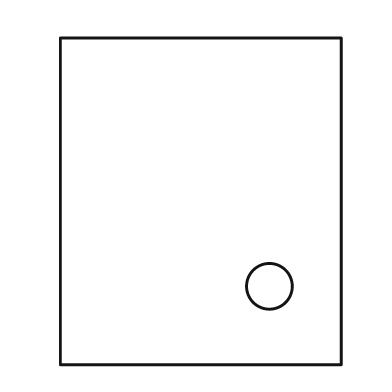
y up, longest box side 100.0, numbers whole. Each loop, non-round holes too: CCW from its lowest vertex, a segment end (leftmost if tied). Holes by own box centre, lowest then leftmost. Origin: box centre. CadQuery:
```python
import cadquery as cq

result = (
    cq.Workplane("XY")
    .moveTo(-43.0, -50.0)
    .lineTo(43.0, -50.0)
    .lineTo(43.0, 50.0)
    .lineTo(-43.0, 50.0)
    .close()
    .moveTo(21.0, -26.0)
    .circle(7.0)
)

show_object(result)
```